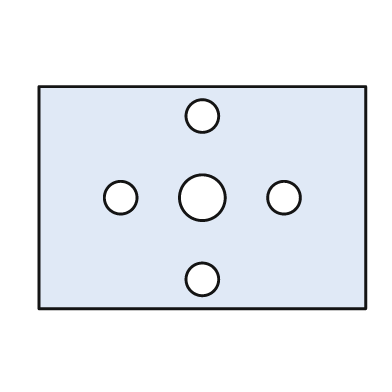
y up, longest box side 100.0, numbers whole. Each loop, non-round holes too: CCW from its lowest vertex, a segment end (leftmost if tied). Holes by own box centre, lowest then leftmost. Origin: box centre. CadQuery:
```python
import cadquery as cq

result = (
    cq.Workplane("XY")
    .moveTo(-50.0, -34.0)
    .lineTo(50.0, -34.0)
    .lineTo(50.0, 34.0)
    .lineTo(-50.0, 34.0)
    .close()
    .moveTo(0.0, -25.0)
    .circle(5.0)
    .moveTo(-25.0, 0.0)
    .circle(5.0)
    .moveTo(0.0, 0.0)
    .circle(7.0)
    .moveTo(25.0, 0.0)
    .circle(5.0)
    .moveTo(0.0, 25.0)
    .circle(5.0)
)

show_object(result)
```